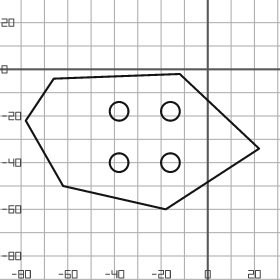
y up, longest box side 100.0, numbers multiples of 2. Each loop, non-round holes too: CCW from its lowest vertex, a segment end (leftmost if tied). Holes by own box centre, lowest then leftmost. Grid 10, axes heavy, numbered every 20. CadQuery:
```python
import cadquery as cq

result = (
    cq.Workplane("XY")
    .moveTo(-18.0, -60.0)
    .lineTo(22.0, -34.0)
    .lineTo(-12.0, -2.0)
    .lineTo(-66.0, -4.0)
    .lineTo(-78.0, -22.0)
    .lineTo(-62.0, -50.0)
    .close()
    .moveTo(-38.0, -40.0)
    .circle(4.0)
    .moveTo(-16.0, -40.0)
    .circle(4.0)
    .moveTo(-38.0, -18.0)
    .circle(4.0)
    .moveTo(-16.0, -18.0)
    .circle(4.0)
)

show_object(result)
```